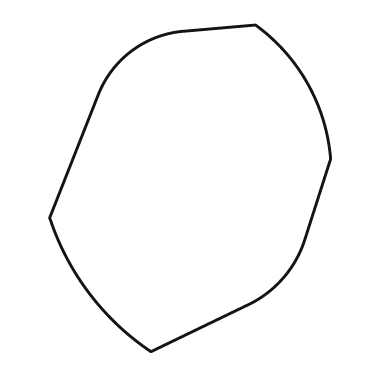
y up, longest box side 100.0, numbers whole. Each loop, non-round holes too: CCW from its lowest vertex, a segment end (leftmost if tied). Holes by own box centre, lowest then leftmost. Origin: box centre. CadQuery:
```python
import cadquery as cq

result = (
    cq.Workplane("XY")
    .moveTo(-12.0, -50.0)
    .lineTo(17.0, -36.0)
    .threePointArc((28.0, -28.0), (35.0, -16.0))
    .lineTo(43.0, 9.0)
    .threePointArc((36.0, 32.0), (20.0, 50.0))
    .lineTo(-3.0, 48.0)
    .threePointArc((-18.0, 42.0), (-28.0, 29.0))
    .lineTo(-43.0, -9.0)
    .threePointArc((-31.0, -32.0), (-12.0, -50.0))
    .close()
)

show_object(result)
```